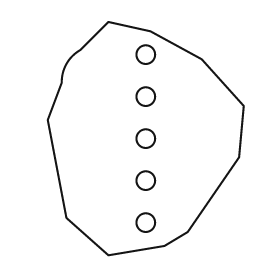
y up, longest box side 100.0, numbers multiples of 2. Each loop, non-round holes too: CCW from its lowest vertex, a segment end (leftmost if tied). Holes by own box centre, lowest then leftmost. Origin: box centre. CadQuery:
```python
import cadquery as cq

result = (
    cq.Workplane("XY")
    .moveTo(-16.0, -50.0)
    .lineTo(8.0, -46.0)
    .lineTo(18.0, -40.0)
    .lineTo(40.0, -8.0)
    .lineTo(42.0, 14.0)
    .lineTo(24.0, 34.0)
    .lineTo(2.0, 46.0)
    .lineTo(-16.0, 50.0)
    .lineTo(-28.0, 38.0)
    .threePointArc((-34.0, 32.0), (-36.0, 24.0))
    .lineTo(-42.0, 8.0)
    .lineTo(-34.0, -34.0)
    .close()
    .moveTo(0.0, -36.0)
    .circle(4.0)
    .moveTo(0.0, -18.0)
    .circle(4.0)
    .moveTo(0.0, 0.0)
    .circle(4.0)
    .moveTo(0.0, 18.0)
    .circle(4.0)
    .moveTo(0.0, 36.0)
    .circle(4.0)
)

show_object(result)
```